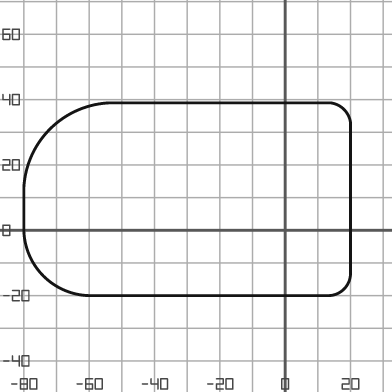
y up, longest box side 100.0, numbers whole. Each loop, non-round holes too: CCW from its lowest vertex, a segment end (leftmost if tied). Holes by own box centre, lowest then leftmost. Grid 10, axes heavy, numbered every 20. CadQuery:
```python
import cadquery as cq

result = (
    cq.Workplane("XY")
    .moveTo(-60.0, -20.0)
    .lineTo(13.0, -20.0)
    .threePointArc((18.0, -18.0), (20.0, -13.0))
    .lineTo(20.0, 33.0)
    .threePointArc((18.0, 37.0), (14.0, 39.0))
    .lineTo(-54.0, 39.0)
    .threePointArc((-72.0, 31.0), (-80.0, 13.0))
    .lineTo(-80.0, 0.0)
    .threePointArc((-74.0, -14.0), (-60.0, -20.0))
    .close()
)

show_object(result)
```